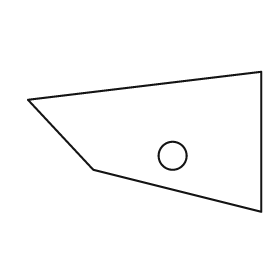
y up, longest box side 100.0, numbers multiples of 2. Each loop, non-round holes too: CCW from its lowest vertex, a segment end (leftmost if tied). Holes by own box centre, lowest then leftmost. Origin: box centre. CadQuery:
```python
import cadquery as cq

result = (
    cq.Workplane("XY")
    .moveTo(50.0, -30.0)
    .lineTo(50.0, 30.0)
    .lineTo(-50.0, 18.0)
    .lineTo(-22.0, -12.0)
    .close()
    .moveTo(12.0, -6.0)
    .circle(6.0)
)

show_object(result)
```